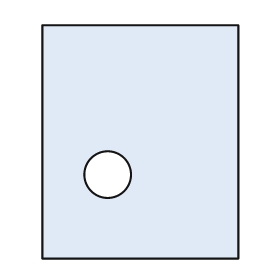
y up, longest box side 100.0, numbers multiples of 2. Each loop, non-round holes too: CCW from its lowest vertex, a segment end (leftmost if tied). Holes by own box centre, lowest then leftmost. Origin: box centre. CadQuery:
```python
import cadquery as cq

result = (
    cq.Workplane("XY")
    .moveTo(-42.0, -50.0)
    .lineTo(42.0, -50.0)
    .lineTo(42.0, 50.0)
    .lineTo(-42.0, 50.0)
    .close()
    .moveTo(-14.0, -14.0)
    .circle(10.0)
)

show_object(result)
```